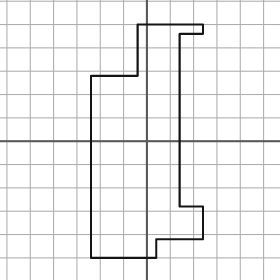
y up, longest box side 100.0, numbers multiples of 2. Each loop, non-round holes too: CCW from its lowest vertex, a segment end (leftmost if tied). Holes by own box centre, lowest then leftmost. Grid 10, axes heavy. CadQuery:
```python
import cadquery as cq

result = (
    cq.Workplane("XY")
    .moveTo(-24.0, -50.0)
    .lineTo(4.0, -50.0)
    .lineTo(4.0, -42.0)
    .lineTo(24.0, -42.0)
    .lineTo(24.0, -28.0)
    .lineTo(14.0, -28.0)
    .lineTo(14.0, 46.0)
    .lineTo(24.0, 46.0)
    .lineTo(24.0, 50.0)
    .lineTo(-4.0, 50.0)
    .lineTo(-4.0, 28.0)
    .lineTo(-24.0, 28.0)
    .close()
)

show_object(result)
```